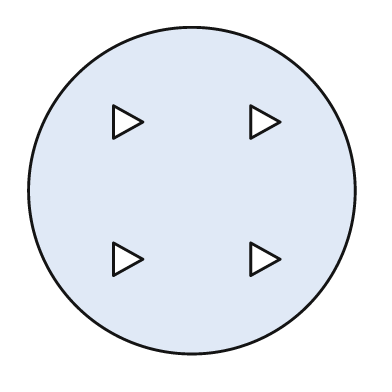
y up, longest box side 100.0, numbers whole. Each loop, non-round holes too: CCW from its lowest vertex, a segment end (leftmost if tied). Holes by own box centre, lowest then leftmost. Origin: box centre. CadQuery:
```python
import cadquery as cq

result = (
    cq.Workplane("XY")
    .moveTo(0.0, 0.0)
    .circle(50.0)
    .moveTo(-24.0, -26.0)
    .lineTo(-15.0, -21.0)
    .lineTo(-24.0, -16.0)
    .close()
    .moveTo(18.0, -26.0)
    .lineTo(27.0, -21.0)
    .lineTo(18.0, -16.0)
    .close()
    .moveTo(-24.0, 16.0)
    .lineTo(-15.0, 21.0)
    .lineTo(-24.0, 26.0)
    .close()
    .moveTo(18.0, 16.0)
    .lineTo(27.0, 21.0)
    .lineTo(18.0, 26.0)
    .close()
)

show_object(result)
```